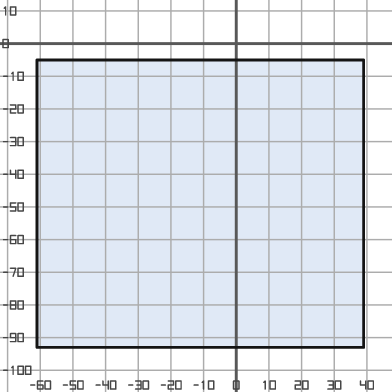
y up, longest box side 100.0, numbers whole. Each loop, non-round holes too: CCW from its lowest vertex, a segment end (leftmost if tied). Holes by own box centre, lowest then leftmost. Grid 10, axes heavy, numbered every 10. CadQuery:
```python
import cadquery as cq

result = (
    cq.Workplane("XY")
    .moveTo(-61.0, -93.0)
    .lineTo(39.0, -93.0)
    .lineTo(39.0, -5.0)
    .lineTo(-61.0, -5.0)
    .close()
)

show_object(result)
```